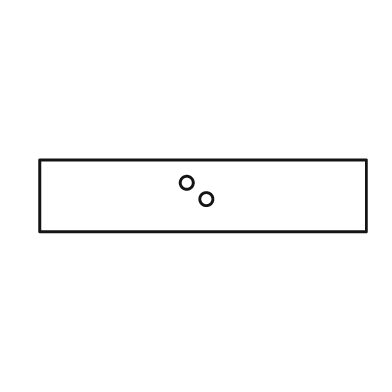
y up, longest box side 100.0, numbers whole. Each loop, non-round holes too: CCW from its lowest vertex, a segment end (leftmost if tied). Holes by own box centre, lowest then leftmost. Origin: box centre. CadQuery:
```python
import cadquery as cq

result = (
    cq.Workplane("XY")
    .moveTo(-50.0, -11.0)
    .lineTo(50.0, -11.0)
    .lineTo(50.0, 11.0)
    .lineTo(-50.0, 11.0)
    .close()
    .moveTo(1.0, -1.0)
    .circle(2.0)
    .moveTo(-5.0, 4.0)
    .circle(2.0)
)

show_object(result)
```